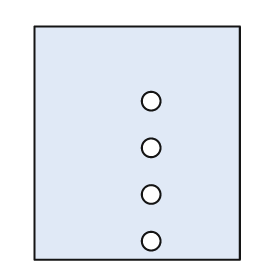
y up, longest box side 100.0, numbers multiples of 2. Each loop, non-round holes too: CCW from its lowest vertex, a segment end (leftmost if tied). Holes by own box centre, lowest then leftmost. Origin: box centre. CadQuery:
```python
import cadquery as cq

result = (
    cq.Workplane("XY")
    .moveTo(-44.0, -50.0)
    .lineTo(44.0, -50.0)
    .lineTo(44.0, 50.0)
    .lineTo(-44.0, 50.0)
    .close()
    .moveTo(6.0, -42.0)
    .circle(4.0)
    .moveTo(6.0, -22.0)
    .circle(4.0)
    .moveTo(6.0, -2.0)
    .circle(4.0)
    .moveTo(6.0, 18.0)
    .circle(4.0)
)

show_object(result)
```